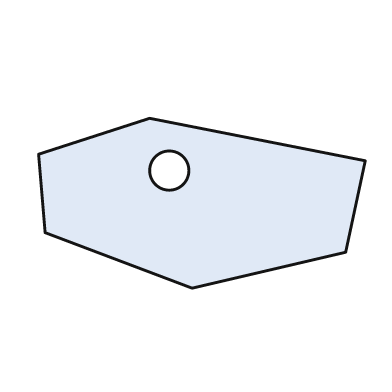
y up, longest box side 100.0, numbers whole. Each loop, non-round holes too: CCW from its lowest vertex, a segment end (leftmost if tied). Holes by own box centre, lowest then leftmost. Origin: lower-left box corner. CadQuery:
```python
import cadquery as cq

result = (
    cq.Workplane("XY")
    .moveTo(47.0, 0.0)
    .lineTo(94.0, 11.0)
    .lineTo(100.0, 39.0)
    .lineTo(34.0, 52.0)
    .lineTo(0.0, 41.0)
    .lineTo(2.0, 17.0)
    .close()
    .moveTo(40.0, 36.0)
    .circle(6.0)
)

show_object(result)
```